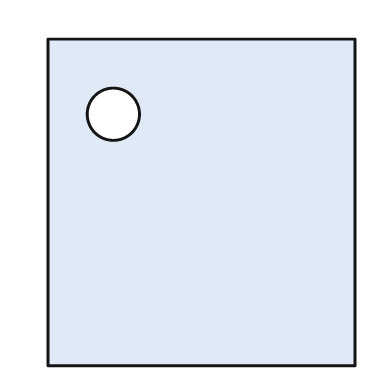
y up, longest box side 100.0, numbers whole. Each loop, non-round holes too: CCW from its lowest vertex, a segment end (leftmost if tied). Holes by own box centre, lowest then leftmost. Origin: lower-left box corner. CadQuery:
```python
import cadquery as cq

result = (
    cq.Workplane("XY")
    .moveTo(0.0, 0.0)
    .lineTo(94.0, 0.0)
    .lineTo(94.0, 100.0)
    .lineTo(0.0, 100.0)
    .close()
    .moveTo(20.0, 77.0)
    .circle(8.0)
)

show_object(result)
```